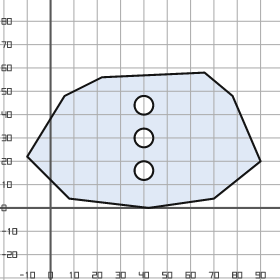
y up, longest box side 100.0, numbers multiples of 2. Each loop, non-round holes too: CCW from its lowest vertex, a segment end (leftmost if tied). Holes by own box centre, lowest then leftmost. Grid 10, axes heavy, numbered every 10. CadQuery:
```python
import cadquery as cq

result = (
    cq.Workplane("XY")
    .moveTo(42.0, 0.0)
    .lineTo(70.0, 4.0)
    .lineTo(90.0, 20.0)
    .lineTo(78.0, 48.0)
    .lineTo(66.0, 58.0)
    .lineTo(22.0, 56.0)
    .lineTo(6.0, 48.0)
    .lineTo(-10.0, 22.0)
    .lineTo(8.0, 4.0)
    .close()
    .moveTo(40.0, 16.0)
    .circle(4.0)
    .moveTo(40.0, 30.0)
    .circle(4.0)
    .moveTo(40.0, 44.0)
    .circle(4.0)
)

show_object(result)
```